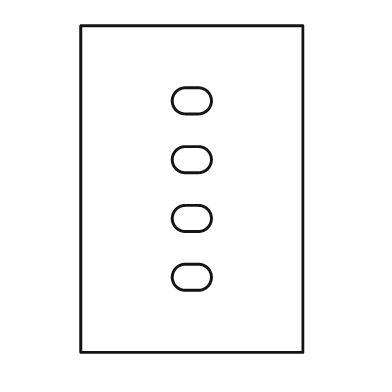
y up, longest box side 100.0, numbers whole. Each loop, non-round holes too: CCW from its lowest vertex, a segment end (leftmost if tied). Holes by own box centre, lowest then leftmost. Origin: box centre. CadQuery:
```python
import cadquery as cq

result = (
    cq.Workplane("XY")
    .moveTo(-34.0, -50.0)
    .lineTo(34.0, -50.0)
    .lineTo(34.0, 50.0)
    .lineTo(-34.0, 50.0)
    .close()
    .moveTo(-2.0, -31.0)
    .lineTo(2.0, -31.0)
    .threePointArc((6.0, -27.0), (2.0, -23.0))
    .lineTo(-2.0, -23.0)
    .threePointArc((-6.0, -27.0), (-2.0, -31.0))
    .close()
    .moveTo(-2.0, -13.0)
    .lineTo(2.0, -13.0)
    .threePointArc((6.0, -9.0), (2.0, -5.0))
    .lineTo(-2.0, -5.0)
    .threePointArc((-6.0, -9.0), (-2.0, -13.0))
    .close()
    .moveTo(-2.0, 5.0)
    .lineTo(2.0, 5.0)
    .threePointArc((6.0, 9.0), (2.0, 13.0))
    .lineTo(-2.0, 13.0)
    .threePointArc((-6.0, 9.0), (-2.0, 5.0))
    .close()
    .moveTo(-2.0, 23.0)
    .lineTo(2.0, 23.0)
    .threePointArc((6.0, 27.0), (2.0, 31.0))
    .lineTo(-2.0, 31.0)
    .threePointArc((-6.0, 27.0), (-2.0, 23.0))
    .close()
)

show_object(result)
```